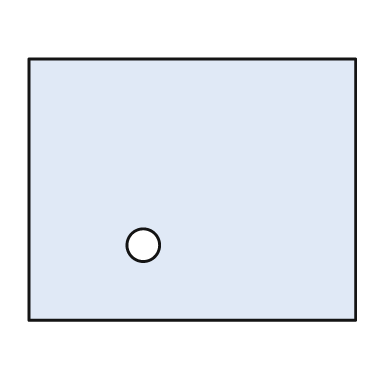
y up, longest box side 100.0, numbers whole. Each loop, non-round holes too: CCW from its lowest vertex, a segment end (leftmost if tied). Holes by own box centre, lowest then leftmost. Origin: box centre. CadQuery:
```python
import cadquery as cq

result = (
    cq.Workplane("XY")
    .moveTo(-50.0, -40.0)
    .lineTo(50.0, -40.0)
    .lineTo(50.0, 40.0)
    .lineTo(-50.0, 40.0)
    .close()
    .moveTo(-15.0, -17.0)
    .circle(5.0)
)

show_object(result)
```